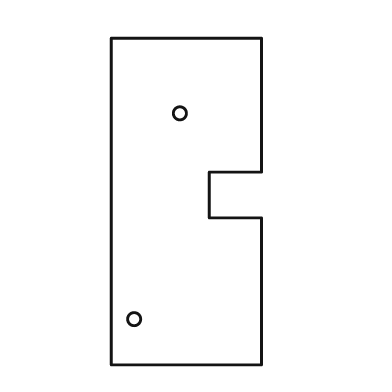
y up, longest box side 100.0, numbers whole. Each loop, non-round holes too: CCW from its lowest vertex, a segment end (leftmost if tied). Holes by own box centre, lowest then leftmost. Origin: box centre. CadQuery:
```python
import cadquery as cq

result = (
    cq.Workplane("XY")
    .moveTo(-23.0, -50.0)
    .lineTo(23.0, -50.0)
    .lineTo(23.0, -5.0)
    .lineTo(7.0, -5.0)
    .lineTo(7.0, 9.0)
    .lineTo(23.0, 9.0)
    .lineTo(23.0, 50.0)
    .lineTo(-23.0, 50.0)
    .close()
    .moveTo(-16.0, -36.0)
    .circle(2.0)
    .moveTo(-2.0, 27.0)
    .circle(2.0)
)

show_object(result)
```